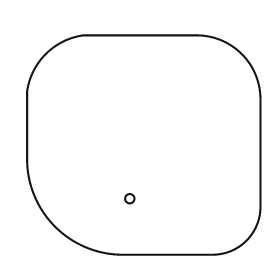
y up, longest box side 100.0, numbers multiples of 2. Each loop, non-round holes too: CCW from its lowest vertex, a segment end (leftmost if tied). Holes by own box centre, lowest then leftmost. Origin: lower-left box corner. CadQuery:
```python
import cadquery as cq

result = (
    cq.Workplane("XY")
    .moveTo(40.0, 0.0)
    .lineTo(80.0, 0.0)
    .threePointArc((94.0, 6.0), (100.0, 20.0))
    .lineTo(100.0, 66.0)
    .threePointArc((92.0, 86.0), (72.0, 94.0))
    .lineTo(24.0, 94.0)
    .threePointArc((8.0, 86.0), (0.0, 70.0))
    .lineTo(0.0, 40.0)
    .threePointArc((12.0, 12.0), (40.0, 0.0))
    .close()
    .moveTo(44.0, 24.0)
    .circle(2.0)
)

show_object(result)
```